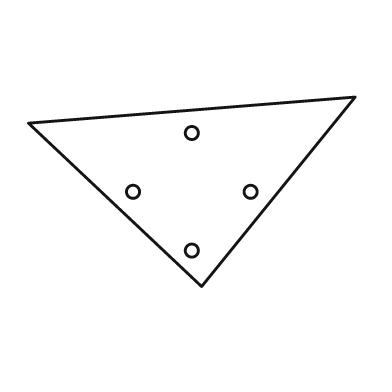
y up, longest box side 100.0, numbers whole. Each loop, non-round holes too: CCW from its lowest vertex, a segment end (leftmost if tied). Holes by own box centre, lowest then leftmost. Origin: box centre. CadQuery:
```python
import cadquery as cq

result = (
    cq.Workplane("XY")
    .moveTo(3.0, -29.0)
    .lineTo(50.0, 29.0)
    .lineTo(-50.0, 21.0)
    .close()
    .moveTo(0.0, -18.0)
    .circle(2.0)
    .moveTo(-18.0, 0.0)
    .circle(2.0)
    .moveTo(18.0, 0.0)
    .circle(2.0)
    .moveTo(0.0, 18.0)
    .circle(2.0)
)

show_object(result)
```